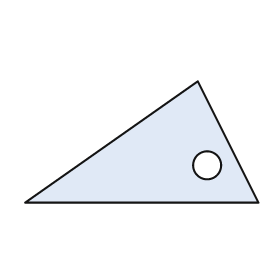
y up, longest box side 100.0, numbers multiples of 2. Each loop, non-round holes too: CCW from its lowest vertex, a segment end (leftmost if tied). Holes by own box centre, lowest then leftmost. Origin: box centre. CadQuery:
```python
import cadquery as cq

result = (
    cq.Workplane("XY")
    .moveTo(-50.0, -26.0)
    .lineTo(50.0, -26.0)
    .lineTo(24.0, 26.0)
    .close()
    .moveTo(28.0, -10.0)
    .circle(6.0)
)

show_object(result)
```